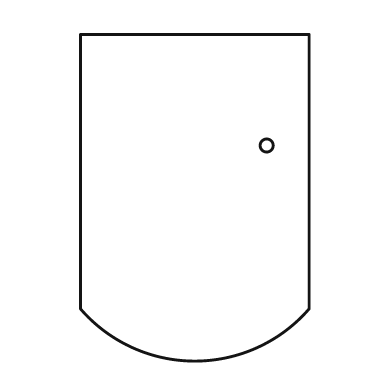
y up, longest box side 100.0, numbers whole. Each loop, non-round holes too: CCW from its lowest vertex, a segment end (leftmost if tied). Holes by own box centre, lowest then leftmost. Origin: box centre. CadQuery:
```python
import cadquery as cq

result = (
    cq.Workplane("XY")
    .moveTo(-35.0, -34.0)
    .threePointArc((0.0, -50.0), (35.0, -34.0))
    .lineTo(35.0, 50.0)
    .lineTo(-35.0, 50.0)
    .close()
    .moveTo(22.0, 16.0)
    .circle(2.0)
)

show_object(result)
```